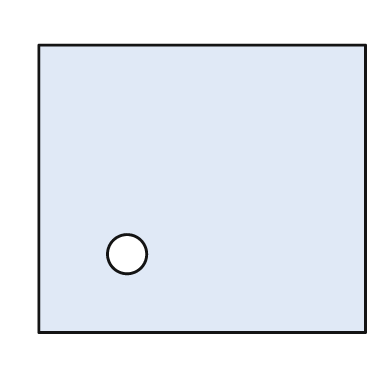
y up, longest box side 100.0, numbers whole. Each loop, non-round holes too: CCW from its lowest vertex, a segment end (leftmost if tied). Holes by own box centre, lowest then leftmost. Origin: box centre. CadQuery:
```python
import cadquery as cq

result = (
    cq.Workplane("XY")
    .moveTo(-50.0, -44.0)
    .lineTo(50.0, -44.0)
    .lineTo(50.0, 44.0)
    .lineTo(-50.0, 44.0)
    .close()
    .moveTo(-23.0, -20.0)
    .circle(6.0)
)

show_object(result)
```